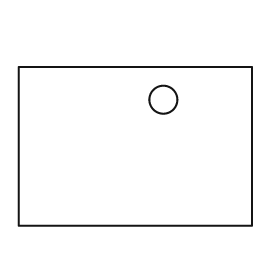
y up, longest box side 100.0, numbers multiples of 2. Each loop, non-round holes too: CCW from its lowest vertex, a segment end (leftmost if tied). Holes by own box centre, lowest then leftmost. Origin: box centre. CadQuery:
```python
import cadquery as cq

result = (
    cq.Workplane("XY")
    .moveTo(-50.0, -34.0)
    .lineTo(50.0, -34.0)
    .lineTo(50.0, 34.0)
    .lineTo(-50.0, 34.0)
    .close()
    .moveTo(12.0, 20.0)
    .circle(6.0)
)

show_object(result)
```